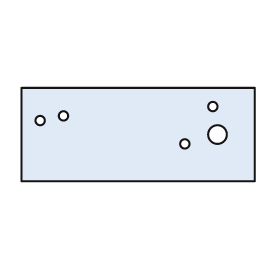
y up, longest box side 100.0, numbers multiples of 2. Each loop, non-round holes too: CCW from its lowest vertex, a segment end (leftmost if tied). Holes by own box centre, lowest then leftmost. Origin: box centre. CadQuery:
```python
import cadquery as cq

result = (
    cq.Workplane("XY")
    .moveTo(-50.0, -20.0)
    .lineTo(50.0, -20.0)
    .lineTo(50.0, 20.0)
    .lineTo(-50.0, 20.0)
    .close()
    .moveTo(20.0, -4.0)
    .circle(2.0)
    .moveTo(34.0, 0.0)
    .circle(4.0)
    .moveTo(-42.0, 6.0)
    .circle(2.0)
    .moveTo(-32.0, 8.0)
    .circle(2.0)
    .moveTo(32.0, 12.0)
    .circle(2.0)
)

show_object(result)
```